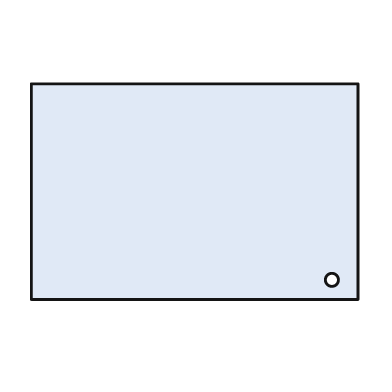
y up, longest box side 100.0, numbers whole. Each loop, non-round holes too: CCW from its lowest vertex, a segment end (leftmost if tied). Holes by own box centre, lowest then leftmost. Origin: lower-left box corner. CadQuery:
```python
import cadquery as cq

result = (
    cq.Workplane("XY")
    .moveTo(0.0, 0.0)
    .lineTo(100.0, 0.0)
    .lineTo(100.0, 66.0)
    .lineTo(0.0, 66.0)
    .close()
    .moveTo(92.0, 6.0)
    .circle(2.0)
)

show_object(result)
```